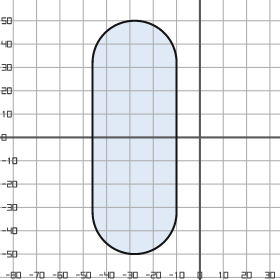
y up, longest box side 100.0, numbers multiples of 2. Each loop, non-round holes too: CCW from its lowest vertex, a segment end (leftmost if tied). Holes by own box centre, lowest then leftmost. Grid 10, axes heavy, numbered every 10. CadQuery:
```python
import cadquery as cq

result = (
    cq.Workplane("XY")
    .moveTo(-46.0, -32.0)
    .threePointArc((-28.0, -50.0), (-10.0, -32.0))
    .lineTo(-10.0, 32.0)
    .threePointArc((-28.0, 50.0), (-46.0, 32.0))
    .close()
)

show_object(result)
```